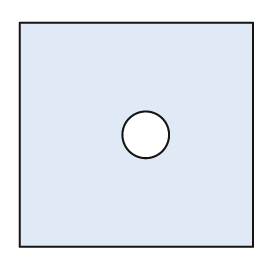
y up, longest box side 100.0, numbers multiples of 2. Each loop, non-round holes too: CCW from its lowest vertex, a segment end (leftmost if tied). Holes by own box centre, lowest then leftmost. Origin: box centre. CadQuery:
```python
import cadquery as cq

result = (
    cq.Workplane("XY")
    .moveTo(-50.0, -48.0)
    .lineTo(50.0, -48.0)
    .lineTo(50.0, 48.0)
    .lineTo(-50.0, 48.0)
    .close()
    .moveTo(4.0, 0.0)
    .circle(10.0)
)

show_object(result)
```